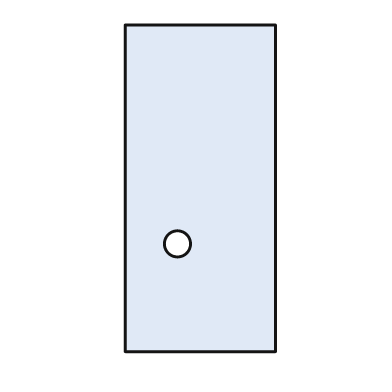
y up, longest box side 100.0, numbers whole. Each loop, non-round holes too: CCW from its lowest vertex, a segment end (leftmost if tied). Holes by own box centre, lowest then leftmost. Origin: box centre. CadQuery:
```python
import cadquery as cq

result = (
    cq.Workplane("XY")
    .moveTo(-23.0, -50.0)
    .lineTo(23.0, -50.0)
    .lineTo(23.0, 50.0)
    .lineTo(-23.0, 50.0)
    .close()
    .moveTo(-7.0, -17.0)
    .circle(4.0)
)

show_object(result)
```